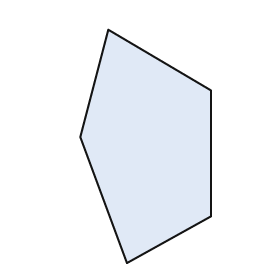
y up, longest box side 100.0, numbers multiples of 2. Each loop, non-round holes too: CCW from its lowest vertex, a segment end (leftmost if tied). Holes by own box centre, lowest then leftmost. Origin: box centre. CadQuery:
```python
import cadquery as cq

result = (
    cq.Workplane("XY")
    .moveTo(-8.0, -50.0)
    .lineTo(28.0, -30.0)
    .lineTo(28.0, 24.0)
    .lineTo(-16.0, 50.0)
    .lineTo(-28.0, 4.0)
    .close()
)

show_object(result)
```